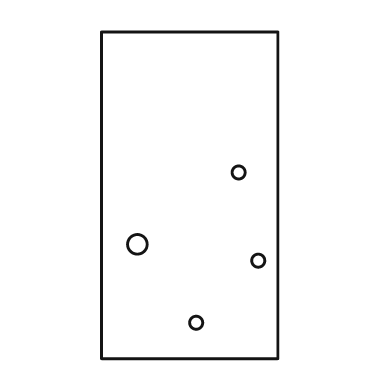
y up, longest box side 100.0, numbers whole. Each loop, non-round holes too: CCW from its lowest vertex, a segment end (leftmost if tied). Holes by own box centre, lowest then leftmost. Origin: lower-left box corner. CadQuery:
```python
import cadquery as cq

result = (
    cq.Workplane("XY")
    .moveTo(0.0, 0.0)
    .lineTo(54.0, 0.0)
    .lineTo(54.0, 100.0)
    .lineTo(0.0, 100.0)
    .close()
    .moveTo(29.0, 11.0)
    .circle(2.0)
    .moveTo(48.0, 30.0)
    .circle(2.0)
    .moveTo(11.0, 35.0)
    .circle(3.0)
    .moveTo(42.0, 57.0)
    .circle(2.0)
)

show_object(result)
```